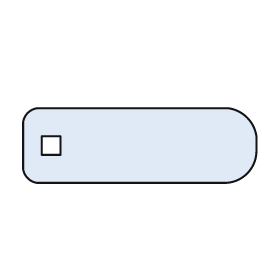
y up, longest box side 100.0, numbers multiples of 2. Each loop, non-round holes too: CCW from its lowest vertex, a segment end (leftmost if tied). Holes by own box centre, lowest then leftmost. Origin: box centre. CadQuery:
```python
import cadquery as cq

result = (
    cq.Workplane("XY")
    .moveTo(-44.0, -16.0)
    .lineTo(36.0, -16.0)
    .threePointArc((46.0, -12.0), (50.0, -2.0))
    .lineTo(50.0, 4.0)
    .threePointArc((46.0, 12.0), (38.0, 16.0))
    .lineTo(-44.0, 16.0)
    .threePointArc((-48.0, 14.0), (-50.0, 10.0))
    .lineTo(-50.0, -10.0)
    .threePointArc((-48.0, -14.0), (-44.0, -16.0))
    .close()
    .moveTo(-42.0, -4.0)
    .lineTo(-34.0, -4.0)
    .lineTo(-34.0, 4.0)
    .lineTo(-42.0, 4.0)
    .close()
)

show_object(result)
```